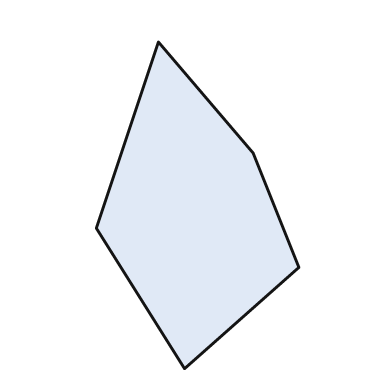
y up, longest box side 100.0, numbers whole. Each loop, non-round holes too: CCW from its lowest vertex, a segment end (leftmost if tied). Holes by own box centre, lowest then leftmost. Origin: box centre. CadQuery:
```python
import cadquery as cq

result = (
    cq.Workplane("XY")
    .moveTo(-4.0, -50.0)
    .lineTo(31.0, -19.0)
    .lineTo(17.0, 16.0)
    .lineTo(-12.0, 50.0)
    .lineTo(-31.0, -7.0)
    .close()
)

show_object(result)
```